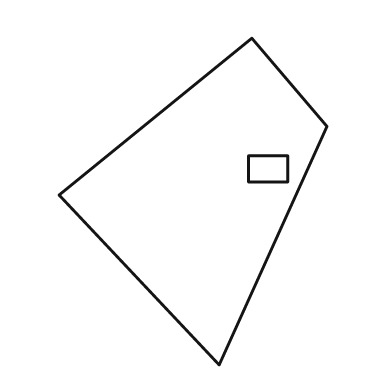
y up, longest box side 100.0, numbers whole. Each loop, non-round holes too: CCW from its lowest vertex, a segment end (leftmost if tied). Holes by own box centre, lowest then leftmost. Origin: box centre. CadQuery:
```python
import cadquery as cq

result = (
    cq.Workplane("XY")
    .moveTo(8.0, -50.0)
    .lineTo(41.0, 23.0)
    .lineTo(18.0, 50.0)
    .lineTo(-41.0, 2.0)
    .close()
    .moveTo(17.0, 6.0)
    .lineTo(29.0, 6.0)
    .lineTo(29.0, 14.0)
    .lineTo(17.0, 14.0)
    .close()
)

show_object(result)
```